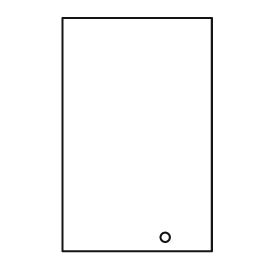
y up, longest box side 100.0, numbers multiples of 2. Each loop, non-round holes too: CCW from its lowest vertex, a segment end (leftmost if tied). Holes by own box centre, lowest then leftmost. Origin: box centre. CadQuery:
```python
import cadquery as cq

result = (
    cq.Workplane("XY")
    .moveTo(-32.0, -50.0)
    .lineTo(32.0, -50.0)
    .lineTo(32.0, 50.0)
    .lineTo(-32.0, 50.0)
    .close()
    .moveTo(12.0, -44.0)
    .circle(2.0)
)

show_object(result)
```